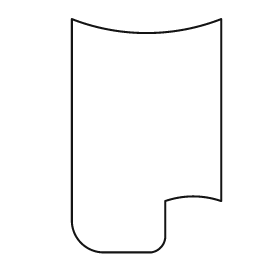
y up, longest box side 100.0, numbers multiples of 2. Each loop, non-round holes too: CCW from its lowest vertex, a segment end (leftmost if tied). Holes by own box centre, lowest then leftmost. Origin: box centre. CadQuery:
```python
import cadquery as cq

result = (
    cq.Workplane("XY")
    .moveTo(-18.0, -50.0)
    .lineTo(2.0, -50.0)
    .threePointArc((6.0, -48.0), (8.0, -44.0))
    .lineTo(8.0, -28.0)
    .threePointArc((20.0, -26.0), (32.0, -28.0))
    .lineTo(32.0, 50.0)
    .threePointArc((0.0, 44.0), (-32.0, 50.0))
    .lineTo(-32.0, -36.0)
    .threePointArc((-28.0, -46.0), (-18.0, -50.0))
    .close()
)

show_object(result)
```